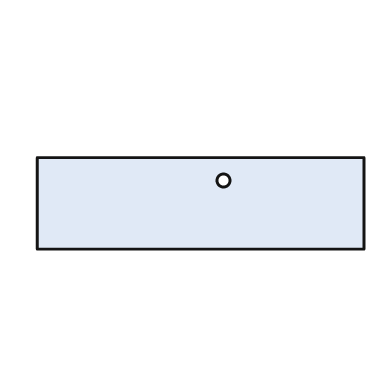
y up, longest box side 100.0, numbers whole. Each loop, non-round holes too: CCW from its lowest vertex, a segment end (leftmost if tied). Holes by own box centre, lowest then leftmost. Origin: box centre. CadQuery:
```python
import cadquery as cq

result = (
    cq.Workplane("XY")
    .moveTo(-50.0, -14.0)
    .lineTo(50.0, -14.0)
    .lineTo(50.0, 14.0)
    .lineTo(-50.0, 14.0)
    .close()
    .moveTo(7.0, 7.0)
    .circle(2.0)
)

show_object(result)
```